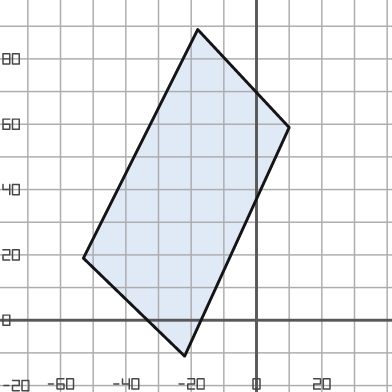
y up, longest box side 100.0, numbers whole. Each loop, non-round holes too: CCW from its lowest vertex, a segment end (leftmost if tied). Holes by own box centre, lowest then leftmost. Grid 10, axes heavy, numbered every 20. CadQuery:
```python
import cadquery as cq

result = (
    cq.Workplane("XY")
    .moveTo(-22.0, -11.0)
    .lineTo(10.0, 59.0)
    .lineTo(-18.0, 89.0)
    .lineTo(-53.0, 19.0)
    .close()
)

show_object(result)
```